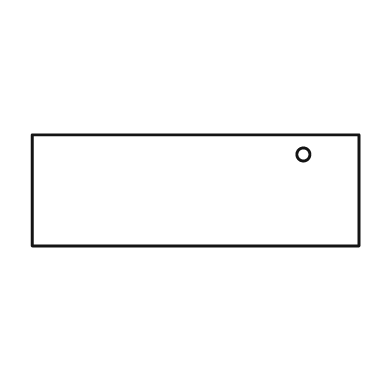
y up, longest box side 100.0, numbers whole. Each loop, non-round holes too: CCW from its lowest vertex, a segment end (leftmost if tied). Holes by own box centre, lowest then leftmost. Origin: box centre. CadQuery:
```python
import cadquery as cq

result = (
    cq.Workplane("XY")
    .moveTo(-50.0, -17.0)
    .lineTo(50.0, -17.0)
    .lineTo(50.0, 17.0)
    .lineTo(-50.0, 17.0)
    .close()
    .moveTo(33.0, 11.0)
    .circle(2.0)
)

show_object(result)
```